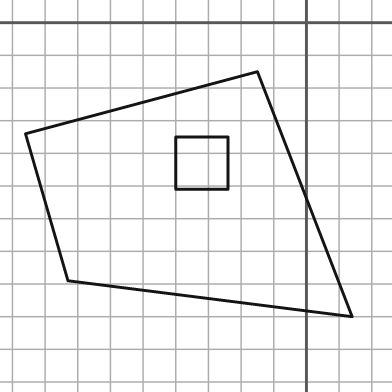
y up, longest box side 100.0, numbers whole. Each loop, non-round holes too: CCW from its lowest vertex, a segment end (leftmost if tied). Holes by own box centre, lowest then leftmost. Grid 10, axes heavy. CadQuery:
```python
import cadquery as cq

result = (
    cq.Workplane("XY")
    .moveTo(14.0, -90.0)
    .lineTo(-15.0, -15.0)
    .lineTo(-86.0, -34.0)
    .lineTo(-73.0, -79.0)
    .close()
    .moveTo(-40.0, -51.0)
    .lineTo(-24.0, -51.0)
    .lineTo(-24.0, -35.0)
    .lineTo(-40.0, -35.0)
    .close()
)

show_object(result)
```